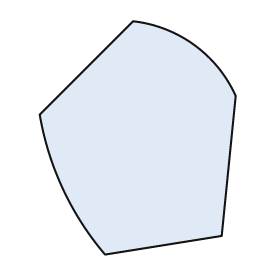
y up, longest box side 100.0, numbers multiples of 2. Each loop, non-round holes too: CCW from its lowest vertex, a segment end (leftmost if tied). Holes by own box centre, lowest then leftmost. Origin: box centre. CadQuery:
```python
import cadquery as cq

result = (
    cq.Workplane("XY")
    .moveTo(-14.0, -50.0)
    .lineTo(36.0, -42.0)
    .lineTo(42.0, 18.0)
    .threePointArc((24.0, 40.0), (-2.0, 50.0))
    .lineTo(-42.0, 10.0)
    .threePointArc((-32.0, -22.0), (-14.0, -50.0))
    .close()
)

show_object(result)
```